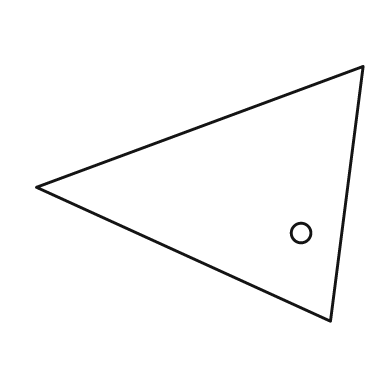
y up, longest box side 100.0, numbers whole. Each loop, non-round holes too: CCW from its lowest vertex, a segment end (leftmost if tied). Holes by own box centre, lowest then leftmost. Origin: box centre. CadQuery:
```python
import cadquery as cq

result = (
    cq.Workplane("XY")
    .moveTo(40.0, -39.0)
    .lineTo(50.0, 39.0)
    .lineTo(-50.0, 2.0)
    .close()
    .moveTo(31.0, -12.0)
    .circle(3.0)
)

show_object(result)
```